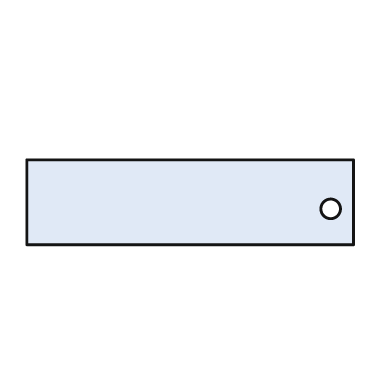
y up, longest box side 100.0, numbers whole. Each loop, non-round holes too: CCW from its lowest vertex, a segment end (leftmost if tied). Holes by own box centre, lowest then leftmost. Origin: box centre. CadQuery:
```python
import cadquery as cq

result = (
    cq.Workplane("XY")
    .moveTo(-50.0, -13.0)
    .lineTo(50.0, -13.0)
    .lineTo(50.0, 13.0)
    .lineTo(-50.0, 13.0)
    .close()
    .moveTo(43.0, -2.0)
    .circle(3.0)
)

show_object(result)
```